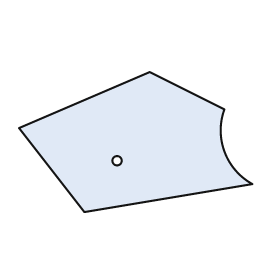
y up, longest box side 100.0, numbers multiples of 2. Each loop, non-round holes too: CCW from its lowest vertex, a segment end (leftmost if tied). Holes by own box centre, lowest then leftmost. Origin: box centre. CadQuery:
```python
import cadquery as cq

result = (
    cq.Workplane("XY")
    .moveTo(-22.0, -30.0)
    .lineTo(50.0, -18.0)
    .threePointArc((38.0, -4.0), (38.0, 14.0))
    .lineTo(6.0, 30.0)
    .lineTo(-50.0, 6.0)
    .close()
    .moveTo(-8.0, -8.0)
    .circle(2.0)
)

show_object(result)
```